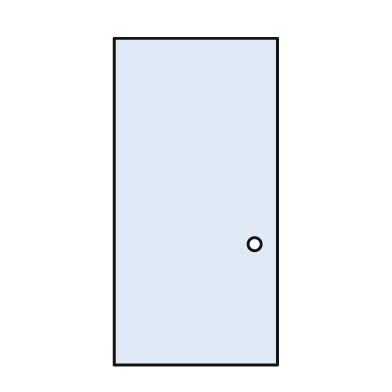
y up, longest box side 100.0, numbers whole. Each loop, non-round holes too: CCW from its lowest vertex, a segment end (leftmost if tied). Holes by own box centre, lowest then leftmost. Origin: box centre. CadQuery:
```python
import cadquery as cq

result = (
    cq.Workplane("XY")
    .moveTo(-25.0, -50.0)
    .lineTo(25.0, -50.0)
    .lineTo(25.0, 50.0)
    .lineTo(-25.0, 50.0)
    .close()
    .moveTo(18.0, -13.0)
    .circle(2.0)
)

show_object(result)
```